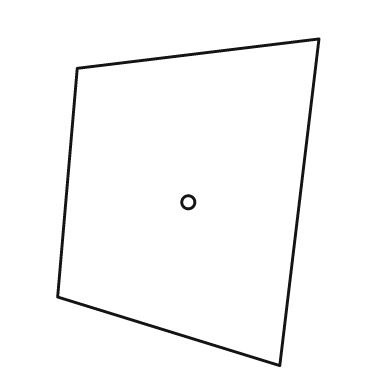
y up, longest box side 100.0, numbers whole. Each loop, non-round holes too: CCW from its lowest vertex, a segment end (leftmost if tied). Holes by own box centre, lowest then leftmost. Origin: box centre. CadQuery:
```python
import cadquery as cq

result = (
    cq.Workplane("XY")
    .moveTo(28.0, -50.0)
    .lineTo(40.0, 50.0)
    .lineTo(-34.0, 41.0)
    .lineTo(-40.0, -29.0)
    .close()
    .moveTo(0.0, 0.0)
    .circle(2.0)
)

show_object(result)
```